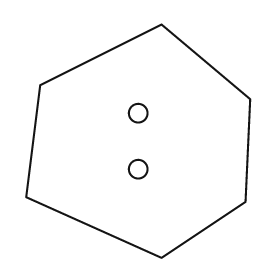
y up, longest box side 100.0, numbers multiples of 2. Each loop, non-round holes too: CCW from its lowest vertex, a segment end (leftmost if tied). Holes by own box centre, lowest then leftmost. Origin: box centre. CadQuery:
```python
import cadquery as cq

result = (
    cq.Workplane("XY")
    .moveTo(10.0, -50.0)
    .lineTo(46.0, -26.0)
    .lineTo(48.0, 18.0)
    .lineTo(10.0, 50.0)
    .lineTo(-42.0, 24.0)
    .lineTo(-48.0, -24.0)
    .close()
    .moveTo(0.0, -12.0)
    .circle(4.0)
    .moveTo(0.0, 12.0)
    .circle(4.0)
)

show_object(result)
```